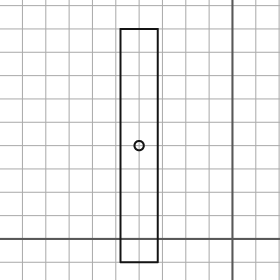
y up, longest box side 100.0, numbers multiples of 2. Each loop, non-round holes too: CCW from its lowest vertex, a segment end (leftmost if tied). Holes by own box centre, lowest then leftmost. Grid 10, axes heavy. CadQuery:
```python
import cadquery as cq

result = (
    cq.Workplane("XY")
    .moveTo(-48.0, -10.0)
    .lineTo(-32.0, -10.0)
    .lineTo(-32.0, 90.0)
    .lineTo(-48.0, 90.0)
    .close()
    .moveTo(-40.0, 40.0)
    .circle(2.0)
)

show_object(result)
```